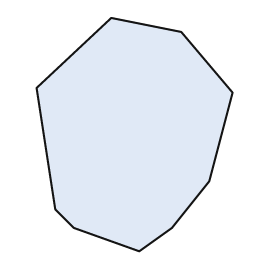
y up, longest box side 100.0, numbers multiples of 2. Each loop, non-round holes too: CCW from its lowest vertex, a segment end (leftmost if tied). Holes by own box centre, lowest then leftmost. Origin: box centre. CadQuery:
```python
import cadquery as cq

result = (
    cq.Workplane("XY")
    .moveTo(2.0, -50.0)
    .lineTo(16.0, -40.0)
    .lineTo(32.0, -20.0)
    .lineTo(42.0, 18.0)
    .lineTo(20.0, 44.0)
    .lineTo(-10.0, 50.0)
    .lineTo(-42.0, 20.0)
    .lineTo(-34.0, -32.0)
    .lineTo(-26.0, -40.0)
    .close()
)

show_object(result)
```